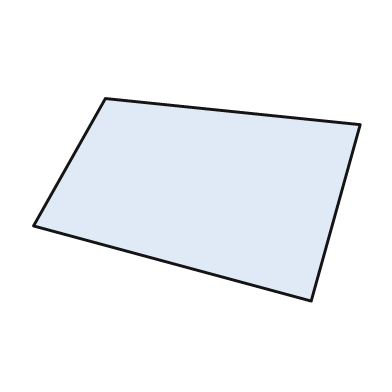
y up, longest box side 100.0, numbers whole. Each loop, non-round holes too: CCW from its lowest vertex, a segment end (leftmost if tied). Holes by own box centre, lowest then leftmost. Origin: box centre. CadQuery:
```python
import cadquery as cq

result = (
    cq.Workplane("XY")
    .moveTo(35.0, -31.0)
    .lineTo(50.0, 23.0)
    .lineTo(-28.0, 31.0)
    .lineTo(-50.0, -8.0)
    .close()
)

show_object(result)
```